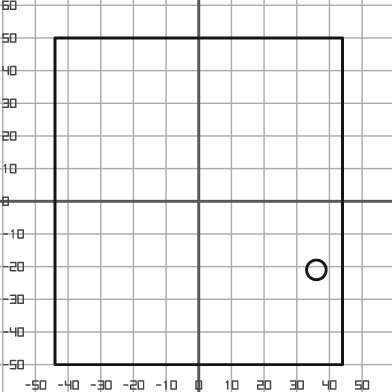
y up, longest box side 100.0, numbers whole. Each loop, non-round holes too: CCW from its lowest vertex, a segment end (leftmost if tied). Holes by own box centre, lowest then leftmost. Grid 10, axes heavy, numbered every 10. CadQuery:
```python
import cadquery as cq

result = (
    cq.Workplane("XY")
    .moveTo(-44.0, -50.0)
    .lineTo(44.0, -50.0)
    .lineTo(44.0, 50.0)
    .lineTo(-44.0, 50.0)
    .close()
    .moveTo(36.0, -21.0)
    .circle(3.0)
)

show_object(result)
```